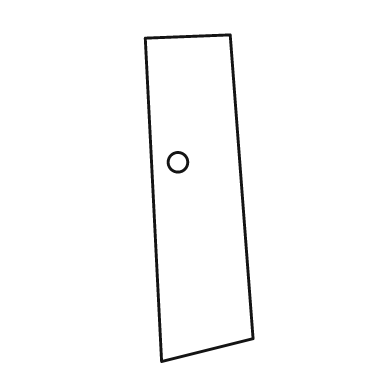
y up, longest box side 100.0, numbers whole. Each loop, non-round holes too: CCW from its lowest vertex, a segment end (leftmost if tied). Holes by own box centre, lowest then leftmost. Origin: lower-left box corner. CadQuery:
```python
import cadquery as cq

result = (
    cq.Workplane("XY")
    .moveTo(5.0, 0.0)
    .lineTo(33.0, 7.0)
    .lineTo(26.0, 100.0)
    .lineTo(0.0, 99.0)
    .close()
    .moveTo(10.0, 61.0)
    .circle(3.0)
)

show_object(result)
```